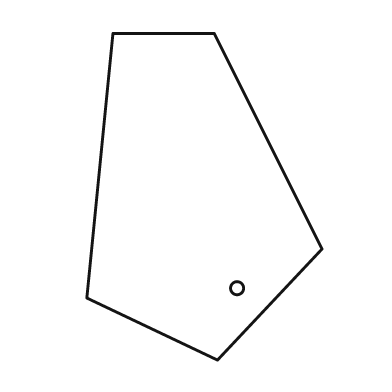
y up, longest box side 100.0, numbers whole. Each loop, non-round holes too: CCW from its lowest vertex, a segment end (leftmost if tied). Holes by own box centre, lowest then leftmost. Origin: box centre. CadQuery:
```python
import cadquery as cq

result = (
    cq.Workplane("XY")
    .moveTo(4.0, -50.0)
    .lineTo(36.0, -16.0)
    .lineTo(3.0, 50.0)
    .lineTo(-28.0, 50.0)
    .lineTo(-36.0, -31.0)
    .close()
    .moveTo(10.0, -28.0)
    .circle(2.0)
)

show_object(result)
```